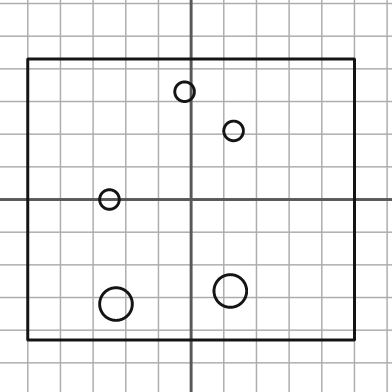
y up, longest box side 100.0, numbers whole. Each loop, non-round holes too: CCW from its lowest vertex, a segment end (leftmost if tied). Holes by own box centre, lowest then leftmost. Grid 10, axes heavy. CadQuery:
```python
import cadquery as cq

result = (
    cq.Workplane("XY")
    .moveTo(-50.0, -43.0)
    .lineTo(50.0, -43.0)
    .lineTo(50.0, 43.0)
    .lineTo(-50.0, 43.0)
    .close()
    .moveTo(-23.0, -32.0)
    .circle(5.0)
    .moveTo(12.0, -28.0)
    .circle(5.0)
    .moveTo(-25.0, 0.0)
    .circle(3.0)
    .moveTo(13.0, 21.0)
    .circle(3.0)
    .moveTo(-2.0, 33.0)
    .circle(3.0)
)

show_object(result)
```